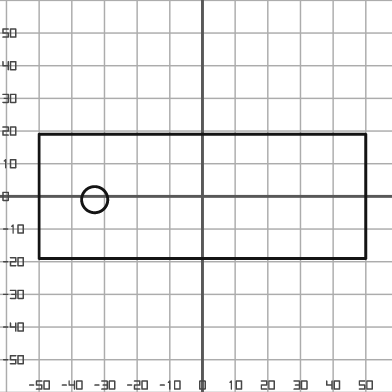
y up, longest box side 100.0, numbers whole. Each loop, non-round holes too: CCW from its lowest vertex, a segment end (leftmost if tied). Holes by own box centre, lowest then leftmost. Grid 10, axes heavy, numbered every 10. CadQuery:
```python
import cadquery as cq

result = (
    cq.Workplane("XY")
    .moveTo(-50.0, -19.0)
    .lineTo(50.0, -19.0)
    .lineTo(50.0, 19.0)
    .lineTo(-50.0, 19.0)
    .close()
    .moveTo(-33.0, -1.0)
    .circle(4.0)
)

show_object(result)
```